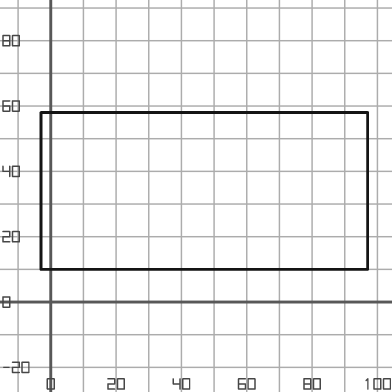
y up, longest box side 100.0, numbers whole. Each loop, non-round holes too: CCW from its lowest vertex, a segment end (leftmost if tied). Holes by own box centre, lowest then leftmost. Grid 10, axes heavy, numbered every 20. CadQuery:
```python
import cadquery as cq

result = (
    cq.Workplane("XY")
    .moveTo(-3.0, 10.0)
    .lineTo(97.0, 10.0)
    .lineTo(97.0, 58.0)
    .lineTo(-3.0, 58.0)
    .close()
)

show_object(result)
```